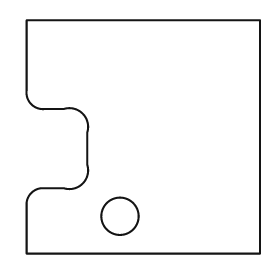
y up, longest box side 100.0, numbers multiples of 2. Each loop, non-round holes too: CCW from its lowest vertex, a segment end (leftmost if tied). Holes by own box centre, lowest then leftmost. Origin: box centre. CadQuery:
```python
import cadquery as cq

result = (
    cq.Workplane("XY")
    .moveTo(-50.0, -50.0)
    .lineTo(50.0, -50.0)
    .lineTo(50.0, 50.0)
    .lineTo(-50.0, 50.0)
    .lineTo(-50.0, 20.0)
    .threePointArc((-48.0, 14.0), (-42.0, 12.0))
    .lineTo(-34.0, 12.0)
    .threePointArc((-26.0, 10.0), (-24.0, 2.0))
    .lineTo(-24.0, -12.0)
    .threePointArc((-26.0, -20.0), (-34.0, -22.0))
    .lineTo(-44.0, -22.0)
    .threePointArc((-48.0, -24.0), (-50.0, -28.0))
    .close()
    .moveTo(-10.0, -34.0)
    .circle(8.0)
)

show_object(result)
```